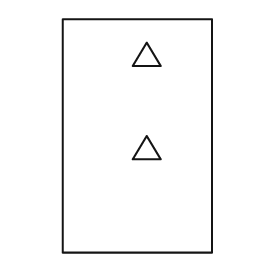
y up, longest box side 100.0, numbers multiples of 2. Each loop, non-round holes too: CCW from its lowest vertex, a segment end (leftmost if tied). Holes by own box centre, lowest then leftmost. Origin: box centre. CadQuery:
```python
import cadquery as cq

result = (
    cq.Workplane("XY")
    .moveTo(-32.0, -50.0)
    .lineTo(32.0, -50.0)
    .lineTo(32.0, 50.0)
    .lineTo(-32.0, 50.0)
    .close()
    .moveTo(-2.0, -10.0)
    .lineTo(10.0, -10.0)
    .lineTo(4.0, 0.0)
    .close()
    .moveTo(-2.0, 30.0)
    .lineTo(10.0, 30.0)
    .lineTo(4.0, 40.0)
    .close()
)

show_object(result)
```